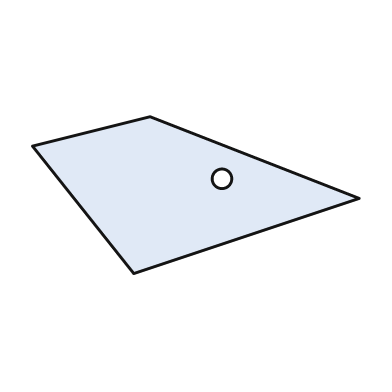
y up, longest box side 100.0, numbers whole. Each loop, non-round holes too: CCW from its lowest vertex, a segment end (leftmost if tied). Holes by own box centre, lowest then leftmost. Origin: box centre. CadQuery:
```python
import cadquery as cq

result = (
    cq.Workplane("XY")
    .moveTo(-19.0, -24.0)
    .lineTo(50.0, -1.0)
    .lineTo(-14.0, 24.0)
    .lineTo(-50.0, 15.0)
    .close()
    .moveTo(8.0, 5.0)
    .circle(3.0)
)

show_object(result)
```